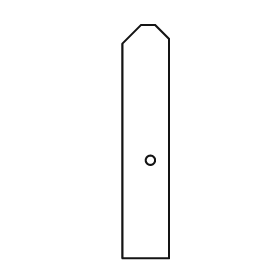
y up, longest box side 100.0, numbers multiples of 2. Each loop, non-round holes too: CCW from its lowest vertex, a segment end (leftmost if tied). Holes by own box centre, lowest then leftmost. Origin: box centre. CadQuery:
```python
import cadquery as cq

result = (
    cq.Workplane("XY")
    .moveTo(-10.0, -50.0)
    .lineTo(10.0, -50.0)
    .lineTo(10.0, 44.0)
    .lineTo(4.0, 50.0)
    .lineTo(-2.0, 50.0)
    .lineTo(-10.0, 42.0)
    .close()
    .moveTo(2.0, -8.0)
    .circle(2.0)
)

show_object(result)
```